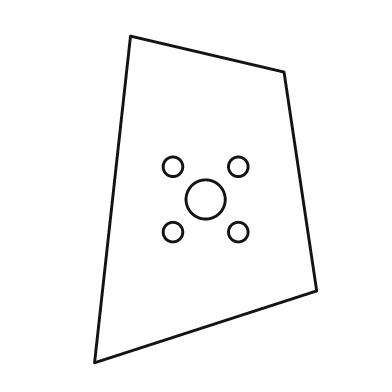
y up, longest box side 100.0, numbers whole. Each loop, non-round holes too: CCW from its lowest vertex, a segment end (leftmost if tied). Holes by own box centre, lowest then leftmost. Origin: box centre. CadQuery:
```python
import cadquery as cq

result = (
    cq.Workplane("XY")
    .moveTo(-34.0, -50.0)
    .lineTo(34.0, -28.0)
    .lineTo(24.0, 39.0)
    .lineTo(-23.0, 50.0)
    .close()
    .moveTo(-10.0, -10.0)
    .circle(3.0)
    .moveTo(10.0, -10.0)
    .circle(3.0)
    .moveTo(0.0, 0.0)
    .circle(6.0)
    .moveTo(-10.0, 10.0)
    .circle(3.0)
    .moveTo(10.0, 10.0)
    .circle(3.0)
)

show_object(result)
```